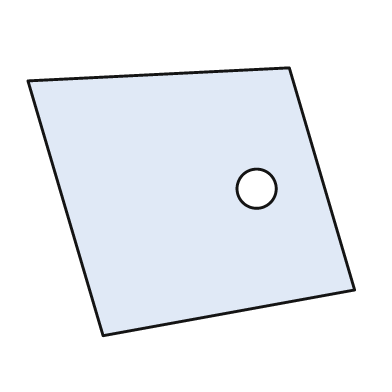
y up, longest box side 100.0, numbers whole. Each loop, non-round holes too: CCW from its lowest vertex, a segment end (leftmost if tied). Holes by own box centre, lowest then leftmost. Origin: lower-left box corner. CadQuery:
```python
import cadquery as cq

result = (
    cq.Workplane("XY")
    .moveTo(23.0, 0.0)
    .lineTo(100.0, 14.0)
    .lineTo(80.0, 82.0)
    .lineTo(0.0, 78.0)
    .close()
    .moveTo(70.0, 45.0)
    .circle(6.0)
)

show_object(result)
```